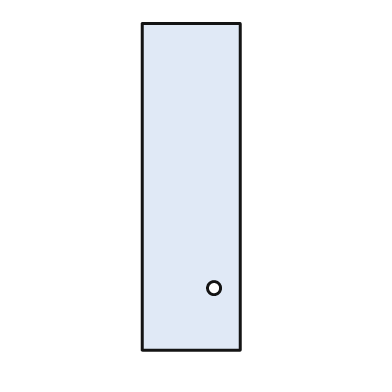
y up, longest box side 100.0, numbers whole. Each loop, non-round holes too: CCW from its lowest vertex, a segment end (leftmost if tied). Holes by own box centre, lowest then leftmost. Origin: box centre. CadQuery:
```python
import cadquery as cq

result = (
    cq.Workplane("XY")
    .moveTo(-15.0, -50.0)
    .lineTo(15.0, -50.0)
    .lineTo(15.0, 50.0)
    .lineTo(-15.0, 50.0)
    .close()
    .moveTo(7.0, -31.0)
    .circle(2.0)
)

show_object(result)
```